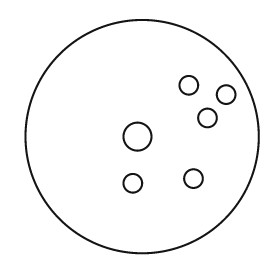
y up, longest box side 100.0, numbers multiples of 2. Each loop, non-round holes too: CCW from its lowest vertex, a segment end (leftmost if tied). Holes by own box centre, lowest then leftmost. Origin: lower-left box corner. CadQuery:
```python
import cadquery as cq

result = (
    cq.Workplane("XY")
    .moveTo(50.0, 50.0)
    .circle(50.0)
    .moveTo(46.0, 30.0)
    .circle(4.0)
    .moveTo(72.0, 32.0)
    .circle(4.0)
    .moveTo(48.0, 50.0)
    .circle(6.0)
    .moveTo(78.0, 58.0)
    .circle(4.0)
    .moveTo(86.0, 68.0)
    .circle(4.0)
    .moveTo(70.0, 72.0)
    .circle(4.0)
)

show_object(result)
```